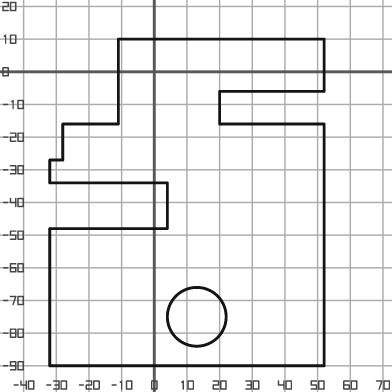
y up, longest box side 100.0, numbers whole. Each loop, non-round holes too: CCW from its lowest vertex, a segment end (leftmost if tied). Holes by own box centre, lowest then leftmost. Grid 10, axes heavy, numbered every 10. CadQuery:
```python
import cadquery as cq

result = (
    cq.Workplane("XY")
    .moveTo(-32.0, -90.0)
    .lineTo(52.0, -90.0)
    .lineTo(52.0, -16.0)
    .lineTo(20.0, -16.0)
    .lineTo(20.0, -6.0)
    .lineTo(52.0, -6.0)
    .lineTo(52.0, 10.0)
    .lineTo(-11.0, 10.0)
    .lineTo(-11.0, -16.0)
    .lineTo(-28.0, -16.0)
    .lineTo(-28.0, -27.0)
    .lineTo(-32.0, -27.0)
    .lineTo(-32.0, -34.0)
    .lineTo(4.0, -34.0)
    .lineTo(4.0, -48.0)
    .lineTo(-32.0, -48.0)
    .close()
    .moveTo(13.0, -75.0)
    .circle(9.0)
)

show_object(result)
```